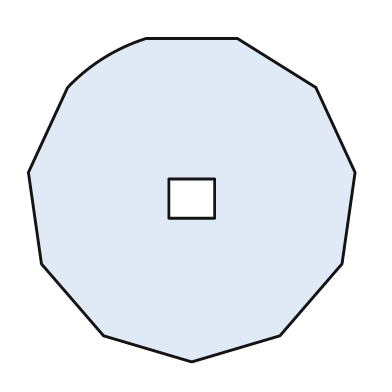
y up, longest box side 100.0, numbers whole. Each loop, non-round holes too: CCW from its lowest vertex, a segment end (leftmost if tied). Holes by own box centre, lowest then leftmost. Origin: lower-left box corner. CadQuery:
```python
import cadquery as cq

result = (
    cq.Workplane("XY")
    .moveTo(50.0, 0.0)
    .lineTo(77.0, 8.0)
    .lineTo(96.0, 30.0)
    .lineTo(100.0, 58.0)
    .lineTo(88.0, 84.0)
    .lineTo(64.0, 99.0)
    .lineTo(36.0, 99.0)
    .threePointArc((23.0, 93.0), (12.0, 84.0))
    .lineTo(0.0, 58.0)
    .lineTo(4.0, 30.0)
    .lineTo(23.0, 8.0)
    .close()
    .moveTo(43.0, 44.0)
    .lineTo(57.0, 44.0)
    .lineTo(57.0, 56.0)
    .lineTo(43.0, 56.0)
    .close()
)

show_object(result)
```